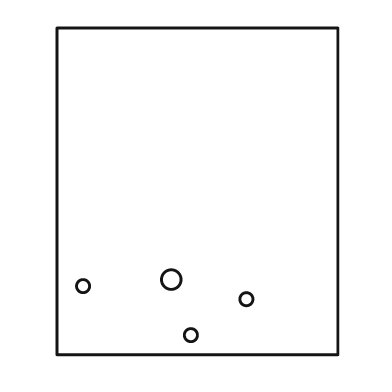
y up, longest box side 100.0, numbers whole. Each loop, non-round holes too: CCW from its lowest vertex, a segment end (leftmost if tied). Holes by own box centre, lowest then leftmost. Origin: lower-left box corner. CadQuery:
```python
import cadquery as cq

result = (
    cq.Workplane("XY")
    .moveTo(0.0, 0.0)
    .lineTo(86.0, 0.0)
    .lineTo(86.0, 100.0)
    .lineTo(0.0, 100.0)
    .close()
    .moveTo(41.0, 6.0)
    .circle(2.0)
    .moveTo(58.0, 17.0)
    .circle(2.0)
    .moveTo(8.0, 21.0)
    .circle(2.0)
    .moveTo(35.0, 23.0)
    .circle(3.0)
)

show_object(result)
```